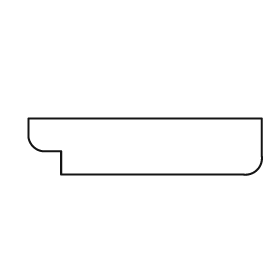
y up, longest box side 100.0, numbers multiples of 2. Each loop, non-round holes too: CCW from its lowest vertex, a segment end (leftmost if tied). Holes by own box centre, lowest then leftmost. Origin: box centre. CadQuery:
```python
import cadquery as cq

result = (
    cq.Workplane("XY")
    .moveTo(-36.0, -12.0)
    .lineTo(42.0, -12.0)
    .threePointArc((48.0, -10.0), (50.0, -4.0))
    .lineTo(50.0, 12.0)
    .lineTo(-50.0, 12.0)
    .lineTo(-50.0, 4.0)
    .threePointArc((-48.0, 0.0), (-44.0, -2.0))
    .lineTo(-36.0, -2.0)
    .close()
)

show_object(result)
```